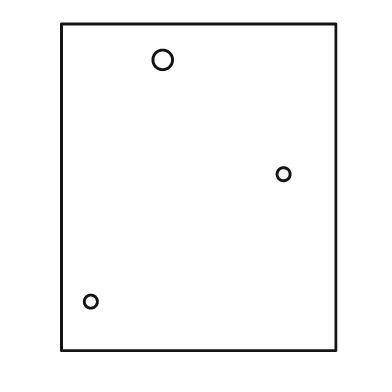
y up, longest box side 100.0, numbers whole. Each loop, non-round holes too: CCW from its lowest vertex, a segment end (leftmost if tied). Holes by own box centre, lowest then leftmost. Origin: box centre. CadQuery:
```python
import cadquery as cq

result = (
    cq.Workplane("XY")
    .moveTo(-42.0, -50.0)
    .lineTo(42.0, -50.0)
    .lineTo(42.0, 50.0)
    .lineTo(-42.0, 50.0)
    .close()
    .moveTo(-33.0, -35.0)
    .circle(2.0)
    .moveTo(26.0, 4.0)
    .circle(2.0)
    .moveTo(-11.0, 39.0)
    .circle(3.0)
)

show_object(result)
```